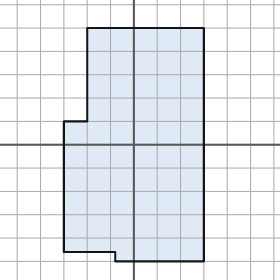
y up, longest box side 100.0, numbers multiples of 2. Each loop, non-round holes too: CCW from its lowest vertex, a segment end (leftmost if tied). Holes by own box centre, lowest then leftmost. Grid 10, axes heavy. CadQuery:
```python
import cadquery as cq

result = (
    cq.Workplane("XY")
    .moveTo(-8.0, -50.0)
    .lineTo(30.0, -50.0)
    .lineTo(30.0, 50.0)
    .lineTo(-20.0, 50.0)
    .lineTo(-20.0, 10.0)
    .lineTo(-30.0, 10.0)
    .lineTo(-30.0, -46.0)
    .lineTo(-8.0, -46.0)
    .close()
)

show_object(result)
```